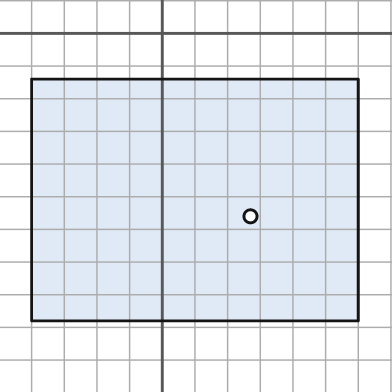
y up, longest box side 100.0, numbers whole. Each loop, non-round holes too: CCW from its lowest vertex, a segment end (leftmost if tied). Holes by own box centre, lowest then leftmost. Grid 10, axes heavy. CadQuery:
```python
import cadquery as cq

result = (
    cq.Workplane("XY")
    .moveTo(-40.0, -88.0)
    .lineTo(60.0, -88.0)
    .lineTo(60.0, -14.0)
    .lineTo(-40.0, -14.0)
    .close()
    .moveTo(27.0, -56.0)
    .circle(2.0)
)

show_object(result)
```